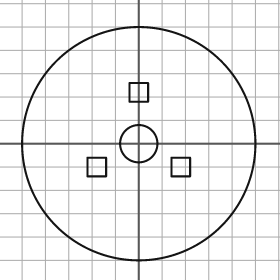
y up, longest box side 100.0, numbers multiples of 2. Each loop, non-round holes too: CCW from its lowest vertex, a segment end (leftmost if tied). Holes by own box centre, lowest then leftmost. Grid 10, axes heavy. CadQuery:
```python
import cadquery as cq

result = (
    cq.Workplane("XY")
    .moveTo(0.0, 0.0)
    .circle(50.0)
    .moveTo(-22.0, -14.0)
    .lineTo(-14.0, -14.0)
    .lineTo(-14.0, -6.0)
    .lineTo(-22.0, -6.0)
    .close()
    .moveTo(14.0, -14.0)
    .lineTo(22.0, -14.0)
    .lineTo(22.0, -6.0)
    .lineTo(14.0, -6.0)
    .close()
    .moveTo(0.0, 0.0)
    .circle(8.0)
    .moveTo(-4.0, 18.0)
    .lineTo(4.0, 18.0)
    .lineTo(4.0, 26.0)
    .lineTo(-4.0, 26.0)
    .close()
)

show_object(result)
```